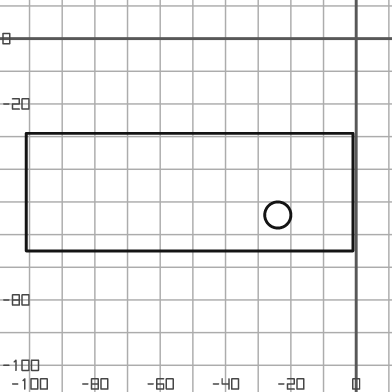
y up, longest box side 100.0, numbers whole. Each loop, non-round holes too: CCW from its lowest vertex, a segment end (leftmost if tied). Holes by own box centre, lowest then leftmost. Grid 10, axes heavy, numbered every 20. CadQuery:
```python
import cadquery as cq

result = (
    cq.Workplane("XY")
    .moveTo(-101.0, -65.0)
    .lineTo(-1.0, -65.0)
    .lineTo(-1.0, -29.0)
    .lineTo(-101.0, -29.0)
    .close()
    .moveTo(-24.0, -54.0)
    .circle(4.0)
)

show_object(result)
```